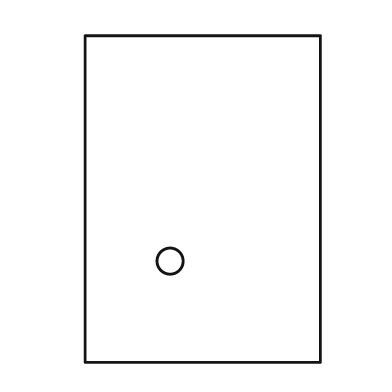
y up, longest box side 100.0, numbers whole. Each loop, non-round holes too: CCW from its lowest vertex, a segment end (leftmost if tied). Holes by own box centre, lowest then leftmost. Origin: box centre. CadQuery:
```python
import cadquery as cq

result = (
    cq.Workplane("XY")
    .moveTo(-36.0, -50.0)
    .lineTo(36.0, -50.0)
    .lineTo(36.0, 50.0)
    .lineTo(-36.0, 50.0)
    .close()
    .moveTo(-10.0, -19.0)
    .circle(4.0)
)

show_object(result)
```